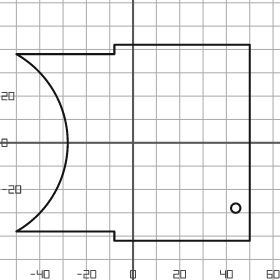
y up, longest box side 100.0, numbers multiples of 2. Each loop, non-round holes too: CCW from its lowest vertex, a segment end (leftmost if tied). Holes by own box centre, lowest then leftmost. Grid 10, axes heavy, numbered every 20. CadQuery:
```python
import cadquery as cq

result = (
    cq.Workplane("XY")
    .moveTo(-8.0, -42.0)
    .lineTo(50.0, -42.0)
    .lineTo(50.0, 42.0)
    .lineTo(-8.0, 42.0)
    .lineTo(-8.0, 38.0)
    .lineTo(-50.0, 38.0)
    .threePointArc((-28.0, 0.0), (-50.0, -38.0))
    .lineTo(-8.0, -38.0)
    .close()
    .moveTo(44.0, -28.0)
    .circle(2.0)
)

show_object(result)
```